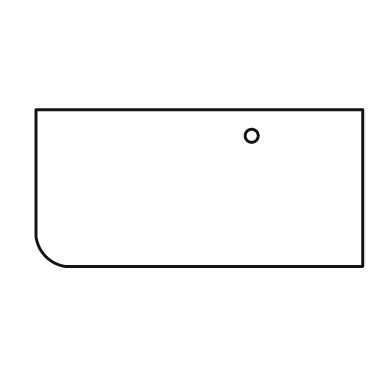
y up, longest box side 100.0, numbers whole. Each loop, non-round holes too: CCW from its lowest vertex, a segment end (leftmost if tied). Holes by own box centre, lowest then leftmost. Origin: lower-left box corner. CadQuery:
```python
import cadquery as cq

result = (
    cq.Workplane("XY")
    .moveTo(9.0, 0.0)
    .lineTo(100.0, 0.0)
    .lineTo(100.0, 48.0)
    .lineTo(0.0, 48.0)
    .lineTo(0.0, 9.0)
    .threePointArc((3.0, 3.0), (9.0, 0.0))
    .close()
    .moveTo(66.0, 40.0)
    .circle(2.0)
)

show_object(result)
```